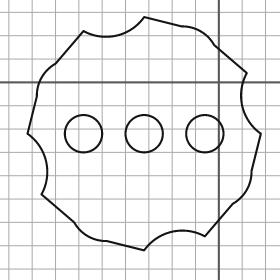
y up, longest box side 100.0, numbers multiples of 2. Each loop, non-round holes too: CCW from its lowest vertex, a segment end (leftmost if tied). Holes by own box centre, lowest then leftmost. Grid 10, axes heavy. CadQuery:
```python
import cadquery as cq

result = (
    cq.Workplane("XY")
    .moveTo(-32.0, -72.0)
    .threePointArc((-20.0, -64.0), (-6.0, -66.0))
    .lineTo(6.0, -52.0)
    .threePointArc((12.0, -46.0), (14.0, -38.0))
    .lineTo(18.0, -22.0)
    .threePointArc((10.0, -10.0), (12.0, 4.0))
    .lineTo(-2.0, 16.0)
    .threePointArc((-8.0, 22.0), (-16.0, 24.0))
    .lineTo(-32.0, 28.0)
    .threePointArc((-44.0, 20.0), (-58.0, 22.0))
    .lineTo(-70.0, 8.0)
    .threePointArc((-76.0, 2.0), (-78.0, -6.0))
    .lineTo(-82.0, -22.0)
    .threePointArc((-74.0, -34.0), (-76.0, -48.0))
    .lineTo(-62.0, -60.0)
    .threePointArc((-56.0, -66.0), (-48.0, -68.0))
    .close()
    .moveTo(-58.0, -22.0)
    .circle(8.0)
    .moveTo(-32.0, -22.0)
    .circle(8.0)
    .moveTo(-6.0, -22.0)
    .circle(8.0)
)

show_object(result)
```